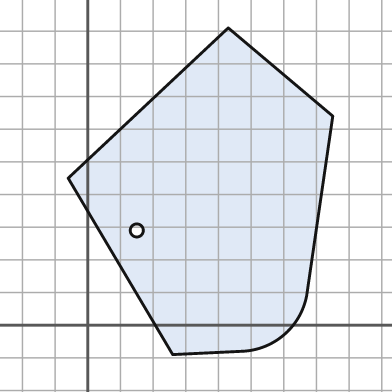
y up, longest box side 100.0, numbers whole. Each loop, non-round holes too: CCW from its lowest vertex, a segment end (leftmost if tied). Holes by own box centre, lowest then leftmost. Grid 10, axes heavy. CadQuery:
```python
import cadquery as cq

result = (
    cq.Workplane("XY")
    .moveTo(26.0, -9.0)
    .lineTo(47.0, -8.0)
    .threePointArc((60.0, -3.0), (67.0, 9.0))
    .lineTo(75.0, 64.0)
    .lineTo(43.0, 91.0)
    .lineTo(-6.0, 45.0)
    .close()
    .moveTo(15.0, 29.0)
    .circle(2.0)
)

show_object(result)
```